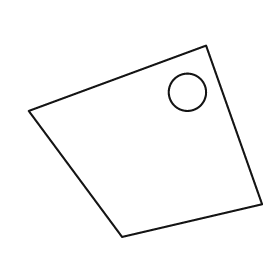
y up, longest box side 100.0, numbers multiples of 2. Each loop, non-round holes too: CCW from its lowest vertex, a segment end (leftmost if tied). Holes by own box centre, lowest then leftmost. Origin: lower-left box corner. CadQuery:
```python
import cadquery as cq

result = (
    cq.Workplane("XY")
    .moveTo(40.0, 0.0)
    .lineTo(100.0, 14.0)
    .lineTo(76.0, 82.0)
    .lineTo(0.0, 54.0)
    .close()
    .moveTo(68.0, 62.0)
    .circle(8.0)
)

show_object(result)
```